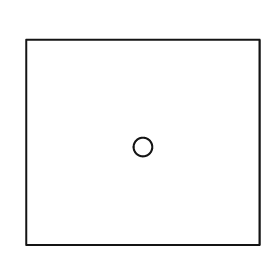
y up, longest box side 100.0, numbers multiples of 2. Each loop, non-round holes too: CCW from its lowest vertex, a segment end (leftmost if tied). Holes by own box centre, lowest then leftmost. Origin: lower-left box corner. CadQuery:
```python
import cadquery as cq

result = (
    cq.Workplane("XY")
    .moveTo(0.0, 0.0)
    .lineTo(100.0, 0.0)
    .lineTo(100.0, 88.0)
    .lineTo(0.0, 88.0)
    .close()
    .moveTo(50.0, 42.0)
    .circle(4.0)
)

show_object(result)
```